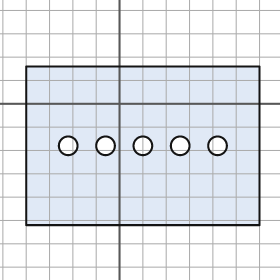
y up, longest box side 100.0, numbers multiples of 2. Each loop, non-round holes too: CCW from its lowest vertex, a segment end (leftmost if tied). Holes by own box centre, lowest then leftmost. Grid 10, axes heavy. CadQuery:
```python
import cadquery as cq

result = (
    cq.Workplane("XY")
    .moveTo(-40.0, -52.0)
    .lineTo(60.0, -52.0)
    .lineTo(60.0, 16.0)
    .lineTo(-40.0, 16.0)
    .close()
    .moveTo(-22.0, -18.0)
    .circle(4.0)
    .moveTo(-6.0, -18.0)
    .circle(4.0)
    .moveTo(10.0, -18.0)
    .circle(4.0)
    .moveTo(26.0, -18.0)
    .circle(4.0)
    .moveTo(42.0, -18.0)
    .circle(4.0)
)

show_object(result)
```